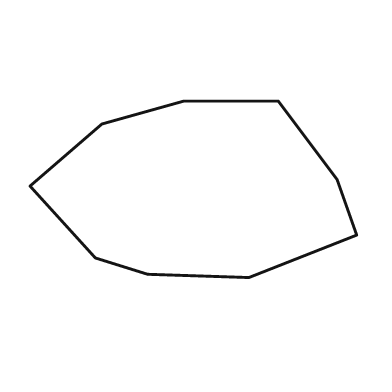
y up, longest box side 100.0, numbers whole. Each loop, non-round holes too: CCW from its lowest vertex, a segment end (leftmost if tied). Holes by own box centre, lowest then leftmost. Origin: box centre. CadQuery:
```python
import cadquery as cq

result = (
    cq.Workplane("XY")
    .moveTo(17.0, -27.0)
    .lineTo(50.0, -14.0)
    .lineTo(44.0, 3.0)
    .lineTo(26.0, 27.0)
    .lineTo(-3.0, 27.0)
    .lineTo(-28.0, 20.0)
    .lineTo(-50.0, 1.0)
    .lineTo(-30.0, -21.0)
    .lineTo(-14.0, -26.0)
    .close()
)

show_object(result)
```